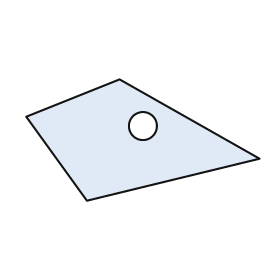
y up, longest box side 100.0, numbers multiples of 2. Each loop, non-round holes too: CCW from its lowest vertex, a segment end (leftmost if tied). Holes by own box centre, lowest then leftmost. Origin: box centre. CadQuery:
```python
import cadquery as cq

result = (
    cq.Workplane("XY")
    .moveTo(-24.0, -26.0)
    .lineTo(50.0, -8.0)
    .lineTo(-10.0, 26.0)
    .lineTo(-50.0, 10.0)
    .close()
    .moveTo(0.0, 6.0)
    .circle(6.0)
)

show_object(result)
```